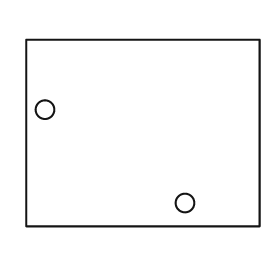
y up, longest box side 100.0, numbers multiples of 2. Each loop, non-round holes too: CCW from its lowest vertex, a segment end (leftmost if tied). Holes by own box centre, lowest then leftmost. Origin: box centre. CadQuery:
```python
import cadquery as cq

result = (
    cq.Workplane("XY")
    .moveTo(-50.0, -40.0)
    .lineTo(50.0, -40.0)
    .lineTo(50.0, 40.0)
    .lineTo(-50.0, 40.0)
    .close()
    .moveTo(18.0, -30.0)
    .circle(4.0)
    .moveTo(-42.0, 10.0)
    .circle(4.0)
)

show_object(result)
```